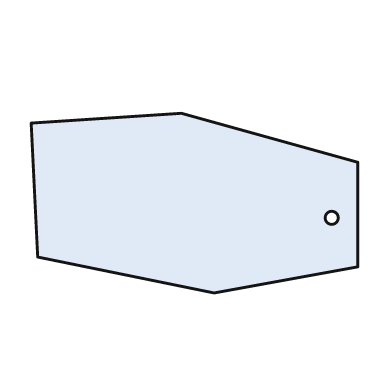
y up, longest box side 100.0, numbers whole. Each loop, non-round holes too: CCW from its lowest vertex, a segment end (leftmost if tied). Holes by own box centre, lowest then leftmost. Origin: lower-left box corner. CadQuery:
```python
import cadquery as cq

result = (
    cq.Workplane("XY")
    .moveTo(56.0, 0.0)
    .lineTo(100.0, 8.0)
    .lineTo(100.0, 40.0)
    .lineTo(46.0, 55.0)
    .lineTo(0.0, 52.0)
    .lineTo(2.0, 11.0)
    .close()
    .moveTo(92.0, 23.0)
    .circle(2.0)
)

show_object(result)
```